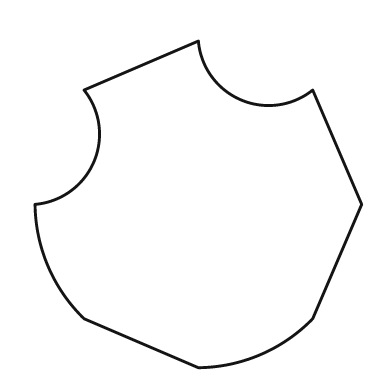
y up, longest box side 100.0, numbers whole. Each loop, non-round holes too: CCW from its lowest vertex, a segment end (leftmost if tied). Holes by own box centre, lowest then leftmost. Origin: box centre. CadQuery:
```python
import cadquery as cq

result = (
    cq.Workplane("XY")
    .moveTo(0.0, -50.0)
    .threePointArc((19.0, -46.0), (35.0, -35.0))
    .lineTo(50.0, 0.0)
    .lineTo(35.0, 35.0)
    .threePointArc((13.0, 32.0), (0.0, 50.0))
    .lineTo(-35.0, 35.0)
    .threePointArc((-32.0, 13.0), (-50.0, 0.0))
    .threePointArc((-46.0, -19.0), (-35.0, -35.0))
    .close()
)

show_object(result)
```